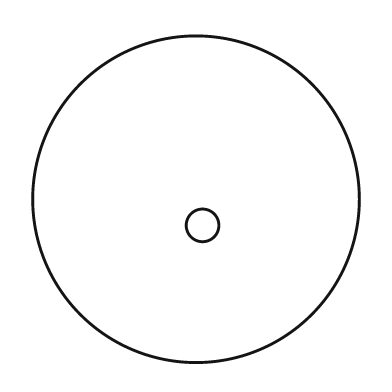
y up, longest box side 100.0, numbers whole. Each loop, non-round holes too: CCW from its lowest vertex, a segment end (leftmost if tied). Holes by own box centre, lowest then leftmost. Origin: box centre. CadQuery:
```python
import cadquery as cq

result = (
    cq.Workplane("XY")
    .moveTo(0.0, 0.0)
    .circle(50.0)
    .moveTo(2.0, -8.0)
    .circle(5.0)
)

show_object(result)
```